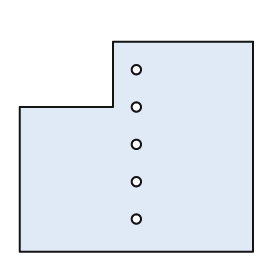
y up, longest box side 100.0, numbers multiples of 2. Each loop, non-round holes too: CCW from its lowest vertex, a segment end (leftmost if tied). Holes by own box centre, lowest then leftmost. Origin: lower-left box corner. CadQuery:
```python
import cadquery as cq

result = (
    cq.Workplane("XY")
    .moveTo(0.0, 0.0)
    .lineTo(100.0, 0.0)
    .lineTo(100.0, 90.0)
    .lineTo(40.0, 90.0)
    .lineTo(40.0, 62.0)
    .lineTo(0.0, 62.0)
    .close()
    .moveTo(50.0, 14.0)
    .circle(2.0)
    .moveTo(50.0, 30.0)
    .circle(2.0)
    .moveTo(50.0, 46.0)
    .circle(2.0)
    .moveTo(50.0, 62.0)
    .circle(2.0)
    .moveTo(50.0, 78.0)
    .circle(2.0)
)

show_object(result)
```